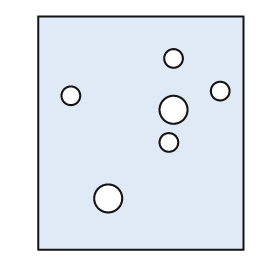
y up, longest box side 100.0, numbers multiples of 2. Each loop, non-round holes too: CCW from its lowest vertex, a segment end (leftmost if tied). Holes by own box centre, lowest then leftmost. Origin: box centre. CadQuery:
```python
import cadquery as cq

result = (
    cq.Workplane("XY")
    .moveTo(-44.0, -50.0)
    .lineTo(44.0, -50.0)
    .lineTo(44.0, 50.0)
    .lineTo(-44.0, 50.0)
    .close()
    .moveTo(-14.0, -28.0)
    .circle(6.0)
    .moveTo(12.0, -4.0)
    .circle(4.0)
    .moveTo(14.0, 10.0)
    .circle(6.0)
    .moveTo(-30.0, 16.0)
    .circle(4.0)
    .moveTo(34.0, 18.0)
    .circle(4.0)
    .moveTo(14.0, 32.0)
    .circle(4.0)
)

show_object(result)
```